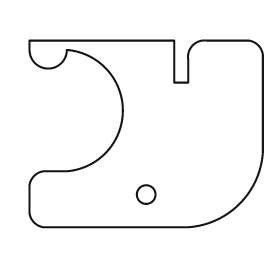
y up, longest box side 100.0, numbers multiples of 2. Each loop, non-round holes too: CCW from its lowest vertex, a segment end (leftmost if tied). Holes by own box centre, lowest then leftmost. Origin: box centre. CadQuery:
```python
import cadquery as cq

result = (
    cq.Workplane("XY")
    .moveTo(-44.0, -40.0)
    .lineTo(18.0, -40.0)
    .threePointArc((40.0, -30.0), (50.0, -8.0))
    .lineTo(50.0, 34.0)
    .threePointArc((48.0, 38.0), (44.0, 40.0))
    .lineTo(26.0, 40.0)
    .threePointArc((20.0, 38.0), (18.0, 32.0))
    .lineTo(18.0, 22.0)
    .lineTo(12.0, 22.0)
    .lineTo(12.0, 40.0)
    .lineTo(-50.0, 40.0)
    .lineTo(-50.0, 36.0)
    .threePointArc((-42.0, 28.0), (-34.0, 36.0))
    .threePointArc((-10.0, 10.0), (-34.0, -16.0))
    .lineTo(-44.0, -16.0)
    .threePointArc((-48.0, -18.0), (-50.0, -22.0))
    .lineTo(-50.0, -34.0)
    .threePointArc((-48.0, -38.0), (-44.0, -40.0))
    .close()
    .moveTo(0.0, -26.0)
    .circle(4.0)
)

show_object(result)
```